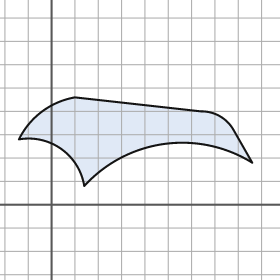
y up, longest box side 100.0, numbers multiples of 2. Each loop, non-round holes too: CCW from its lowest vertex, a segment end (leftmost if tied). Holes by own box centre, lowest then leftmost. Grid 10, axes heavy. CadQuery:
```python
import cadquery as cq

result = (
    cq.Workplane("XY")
    .moveTo(14.0, 8.0)
    .threePointArc((48.0, 26.0), (86.0, 18.0))
    .lineTo(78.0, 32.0)
    .threePointArc((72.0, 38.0), (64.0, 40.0))
    .lineTo(10.0, 46.0)
    .threePointArc((-4.0, 40.0), (-14.0, 28.0))
    .threePointArc((4.0, 24.0), (14.0, 8.0))
    .close()
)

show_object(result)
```